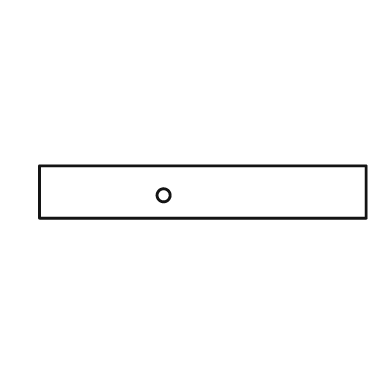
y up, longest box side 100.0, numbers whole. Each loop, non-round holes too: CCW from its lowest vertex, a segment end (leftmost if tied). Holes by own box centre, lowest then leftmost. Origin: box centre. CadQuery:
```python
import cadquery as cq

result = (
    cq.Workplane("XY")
    .moveTo(-50.0, -8.0)
    .lineTo(50.0, -8.0)
    .lineTo(50.0, 8.0)
    .lineTo(-50.0, 8.0)
    .close()
    .moveTo(-12.0, -1.0)
    .circle(2.0)
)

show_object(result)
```